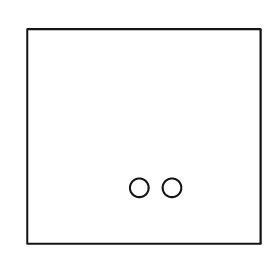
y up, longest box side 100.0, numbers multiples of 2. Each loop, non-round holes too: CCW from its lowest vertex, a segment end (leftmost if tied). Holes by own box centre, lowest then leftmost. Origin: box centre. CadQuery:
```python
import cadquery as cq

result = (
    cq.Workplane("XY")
    .moveTo(-50.0, -46.0)
    .lineTo(50.0, -46.0)
    .lineTo(50.0, 46.0)
    .lineTo(-50.0, 46.0)
    .close()
    .moveTo(-2.0, -22.0)
    .circle(4.0)
    .moveTo(12.0, -22.0)
    .circle(4.0)
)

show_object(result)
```